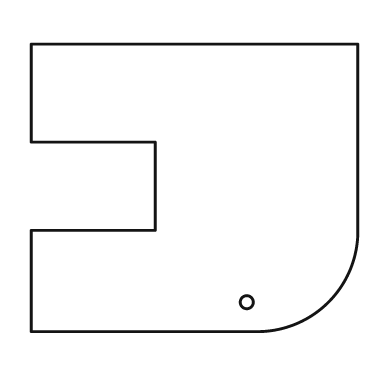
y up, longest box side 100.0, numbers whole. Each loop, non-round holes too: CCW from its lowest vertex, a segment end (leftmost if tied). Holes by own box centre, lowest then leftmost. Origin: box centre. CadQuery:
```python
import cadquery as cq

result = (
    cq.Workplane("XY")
    .moveTo(-50.0, -44.0)
    .lineTo(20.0, -44.0)
    .threePointArc((41.0, -35.0), (50.0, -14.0))
    .lineTo(50.0, 44.0)
    .lineTo(-50.0, 44.0)
    .lineTo(-50.0, 14.0)
    .lineTo(-12.0, 14.0)
    .lineTo(-12.0, -13.0)
    .lineTo(-50.0, -13.0)
    .close()
    .moveTo(16.0, -35.0)
    .circle(2.0)
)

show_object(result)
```